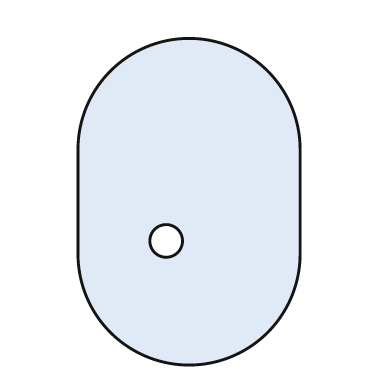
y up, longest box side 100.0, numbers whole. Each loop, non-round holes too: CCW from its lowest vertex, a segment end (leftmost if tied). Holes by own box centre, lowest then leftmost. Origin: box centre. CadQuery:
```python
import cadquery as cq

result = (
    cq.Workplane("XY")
    .moveTo(-34.0, -16.0)
    .threePointArc((0.0, -50.0), (34.0, -16.0))
    .lineTo(34.0, 16.0)
    .threePointArc((0.0, 50.0), (-34.0, 16.0))
    .close()
    .moveTo(-7.0, -12.0)
    .circle(5.0)
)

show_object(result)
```